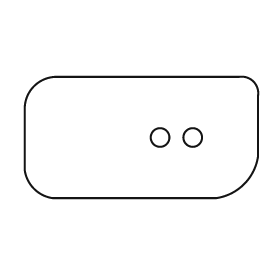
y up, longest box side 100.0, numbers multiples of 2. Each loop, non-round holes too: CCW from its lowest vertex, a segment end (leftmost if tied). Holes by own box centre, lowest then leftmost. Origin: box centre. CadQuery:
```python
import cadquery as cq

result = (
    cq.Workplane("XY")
    .moveTo(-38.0, -26.0)
    .lineTo(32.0, -26.0)
    .threePointArc((44.0, -20.0), (50.0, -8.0))
    .lineTo(50.0, 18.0)
    .threePointArc((48.0, 24.0), (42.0, 26.0))
    .lineTo(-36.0, 26.0)
    .threePointArc((-46.0, 22.0), (-50.0, 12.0))
    .lineTo(-50.0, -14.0)
    .threePointArc((-46.0, -22.0), (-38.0, -26.0))
    .close()
    .moveTo(8.0, 0.0)
    .circle(4.0)
    .moveTo(22.0, 0.0)
    .circle(4.0)
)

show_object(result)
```